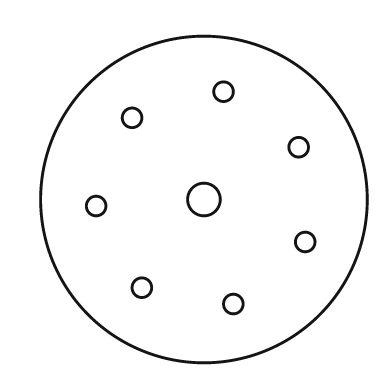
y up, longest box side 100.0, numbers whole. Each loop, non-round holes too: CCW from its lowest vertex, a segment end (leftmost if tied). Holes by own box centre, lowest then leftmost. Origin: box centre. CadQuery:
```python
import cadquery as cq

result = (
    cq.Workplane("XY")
    .moveTo(0.0, 0.0)
    .circle(50.0)
    .moveTo(9.0, -32.0)
    .circle(3.0)
    .moveTo(-19.0, -27.0)
    .circle(3.0)
    .moveTo(31.0, -13.0)
    .circle(3.0)
    .moveTo(-33.0, -2.0)
    .circle(3.0)
    .moveTo(0.0, 0.0)
    .circle(5.0)
    .moveTo(29.0, 16.0)
    .circle(3.0)
    .moveTo(-22.0, 25.0)
    .circle(3.0)
    .moveTo(6.0, 33.0)
    .circle(3.0)
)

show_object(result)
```